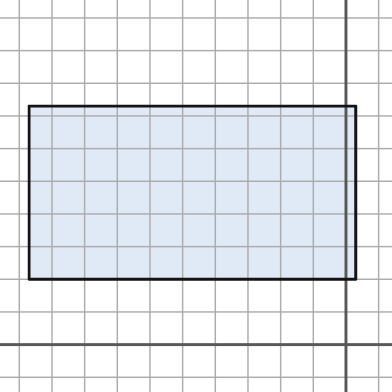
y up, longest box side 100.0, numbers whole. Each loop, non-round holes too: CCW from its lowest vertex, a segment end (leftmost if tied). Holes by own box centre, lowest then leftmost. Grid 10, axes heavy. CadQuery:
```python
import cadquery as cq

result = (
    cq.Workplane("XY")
    .moveTo(-97.0, 20.0)
    .lineTo(3.0, 20.0)
    .lineTo(3.0, 73.0)
    .lineTo(-97.0, 73.0)
    .close()
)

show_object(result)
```